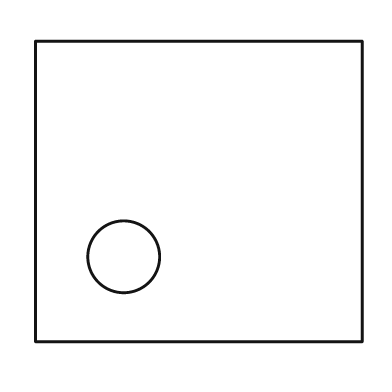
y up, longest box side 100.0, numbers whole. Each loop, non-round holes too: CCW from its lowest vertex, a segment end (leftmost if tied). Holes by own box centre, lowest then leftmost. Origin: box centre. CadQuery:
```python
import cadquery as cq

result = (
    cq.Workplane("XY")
    .moveTo(-50.0, -46.0)
    .lineTo(50.0, -46.0)
    .lineTo(50.0, 46.0)
    .lineTo(-50.0, 46.0)
    .close()
    .moveTo(-23.0, -20.0)
    .circle(11.0)
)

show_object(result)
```